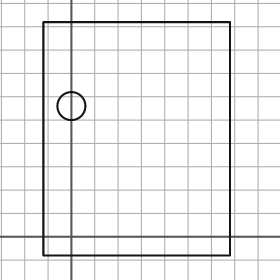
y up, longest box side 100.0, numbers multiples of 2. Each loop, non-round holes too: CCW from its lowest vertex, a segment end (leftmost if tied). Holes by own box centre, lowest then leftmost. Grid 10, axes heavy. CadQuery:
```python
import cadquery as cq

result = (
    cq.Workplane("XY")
    .moveTo(-12.0, -8.0)
    .lineTo(68.0, -8.0)
    .lineTo(68.0, 92.0)
    .lineTo(-12.0, 92.0)
    .close()
    .moveTo(0.0, 56.0)
    .circle(6.0)
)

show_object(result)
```